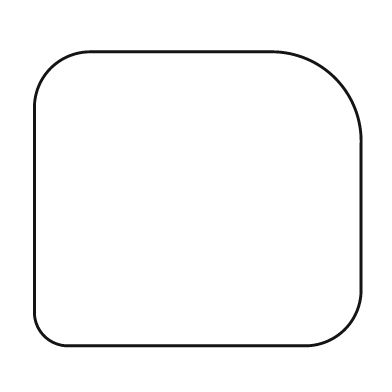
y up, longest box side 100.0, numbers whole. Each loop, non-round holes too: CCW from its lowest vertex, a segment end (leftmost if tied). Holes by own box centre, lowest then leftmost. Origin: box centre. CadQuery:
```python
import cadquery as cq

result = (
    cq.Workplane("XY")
    .moveTo(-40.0, -45.0)
    .lineTo(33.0, -45.0)
    .threePointArc((45.0, -40.0), (50.0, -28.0))
    .lineTo(50.0, 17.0)
    .threePointArc((42.0, 37.0), (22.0, 45.0))
    .lineTo(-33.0, 45.0)
    .threePointArc((-45.0, 40.0), (-50.0, 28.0))
    .lineTo(-50.0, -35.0)
    .threePointArc((-47.0, -42.0), (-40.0, -45.0))
    .close()
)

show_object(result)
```